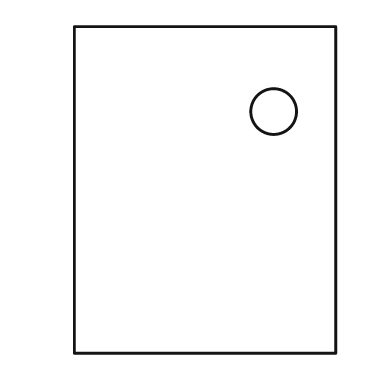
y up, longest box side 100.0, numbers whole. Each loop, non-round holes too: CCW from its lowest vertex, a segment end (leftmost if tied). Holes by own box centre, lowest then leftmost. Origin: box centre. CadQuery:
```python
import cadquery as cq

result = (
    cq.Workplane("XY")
    .moveTo(-40.0, -50.0)
    .lineTo(40.0, -50.0)
    .lineTo(40.0, 50.0)
    .lineTo(-40.0, 50.0)
    .close()
    .moveTo(21.0, 24.0)
    .circle(7.0)
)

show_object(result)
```